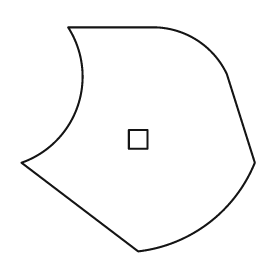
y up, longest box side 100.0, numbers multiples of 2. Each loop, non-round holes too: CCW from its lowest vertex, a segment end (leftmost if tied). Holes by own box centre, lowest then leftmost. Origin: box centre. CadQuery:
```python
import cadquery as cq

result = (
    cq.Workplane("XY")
    .moveTo(0.0, -48.0)
    .threePointArc((30.0, -36.0), (50.0, -10.0))
    .lineTo(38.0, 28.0)
    .threePointArc((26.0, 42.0), (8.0, 48.0))
    .lineTo(-30.0, 48.0)
    .threePointArc((-26.0, 14.0), (-50.0, -10.0))
    .close()
    .moveTo(-4.0, -4.0)
    .lineTo(4.0, -4.0)
    .lineTo(4.0, 4.0)
    .lineTo(-4.0, 4.0)
    .close()
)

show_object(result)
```